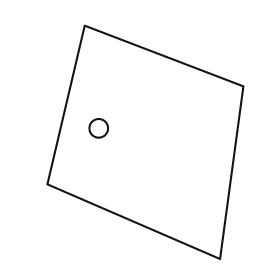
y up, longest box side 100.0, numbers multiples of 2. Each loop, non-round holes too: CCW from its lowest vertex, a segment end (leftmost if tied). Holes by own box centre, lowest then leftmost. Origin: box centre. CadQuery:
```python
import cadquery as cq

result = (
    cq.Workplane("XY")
    .moveTo(32.0, -50.0)
    .lineTo(42.0, 24.0)
    .lineTo(-26.0, 50.0)
    .lineTo(-42.0, -18.0)
    .close()
    .moveTo(-20.0, 6.0)
    .circle(4.0)
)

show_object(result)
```